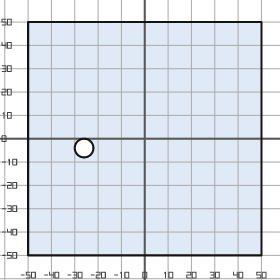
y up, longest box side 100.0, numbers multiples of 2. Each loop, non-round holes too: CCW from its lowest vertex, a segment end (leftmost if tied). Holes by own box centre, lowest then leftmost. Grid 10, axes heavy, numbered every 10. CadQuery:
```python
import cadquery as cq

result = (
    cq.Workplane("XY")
    .moveTo(-50.0, -50.0)
    .lineTo(50.0, -50.0)
    .lineTo(50.0, 50.0)
    .lineTo(-50.0, 50.0)
    .close()
    .moveTo(-26.0, -4.0)
    .circle(4.0)
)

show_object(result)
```